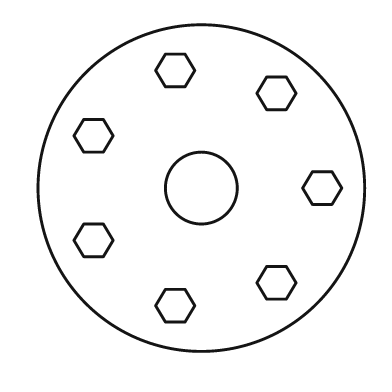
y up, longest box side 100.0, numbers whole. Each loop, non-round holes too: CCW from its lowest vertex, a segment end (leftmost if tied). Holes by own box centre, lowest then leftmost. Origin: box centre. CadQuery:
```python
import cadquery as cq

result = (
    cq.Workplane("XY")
    .moveTo(0.0, 0.0)
    .circle(50.0)
    .moveTo(-11.0, -41.0)
    .lineTo(-5.0, -41.0)
    .lineTo(-2.0, -36.0)
    .lineTo(-5.0, -31.0)
    .lineTo(-11.0, -31.0)
    .lineTo(-14.0, -36.0)
    .close()
    .moveTo(20.0, -34.0)
    .lineTo(26.0, -34.0)
    .lineTo(29.0, -29.0)
    .lineTo(26.0, -24.0)
    .lineTo(20.0, -24.0)
    .lineTo(17.0, -29.0)
    .close()
    .moveTo(-36.0, -21.0)
    .lineTo(-30.0, -21.0)
    .lineTo(-27.0, -16.0)
    .lineTo(-30.0, -11.0)
    .lineTo(-36.0, -11.0)
    .lineTo(-39.0, -16.0)
    .close()
    .moveTo(0.0, 0.0)
    .circle(11.0)
    .moveTo(34.0, -5.0)
    .lineTo(40.0, -5.0)
    .lineTo(43.0, 0.0)
    .lineTo(40.0, 5.0)
    .lineTo(34.0, 5.0)
    .lineTo(31.0, 0.0)
    .close()
    .moveTo(-36.0, 11.0)
    .lineTo(-30.0, 11.0)
    .lineTo(-27.0, 16.0)
    .lineTo(-30.0, 21.0)
    .lineTo(-36.0, 21.0)
    .lineTo(-39.0, 16.0)
    .close()
    .moveTo(20.0, 24.0)
    .lineTo(26.0, 24.0)
    .lineTo(29.0, 29.0)
    .lineTo(26.0, 34.0)
    .lineTo(20.0, 34.0)
    .lineTo(17.0, 29.0)
    .close()
    .moveTo(-11.0, 31.0)
    .lineTo(-5.0, 31.0)
    .lineTo(-2.0, 36.0)
    .lineTo(-5.0, 41.0)
    .lineTo(-11.0, 41.0)
    .lineTo(-14.0, 36.0)
    .close()
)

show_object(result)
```